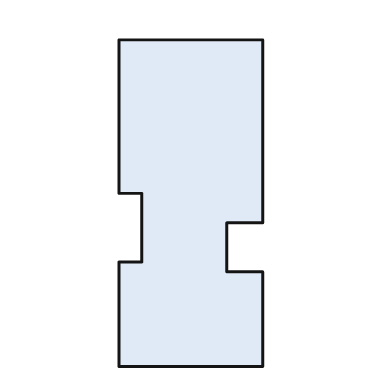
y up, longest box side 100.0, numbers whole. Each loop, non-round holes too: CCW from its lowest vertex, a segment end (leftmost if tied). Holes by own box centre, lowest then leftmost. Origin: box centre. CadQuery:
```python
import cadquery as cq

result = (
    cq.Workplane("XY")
    .moveTo(-22.0, -50.0)
    .lineTo(22.0, -50.0)
    .lineTo(22.0, -21.0)
    .lineTo(11.0, -21.0)
    .lineTo(11.0, -6.0)
    .lineTo(22.0, -6.0)
    .lineTo(22.0, 50.0)
    .lineTo(-22.0, 50.0)
    .lineTo(-22.0, 3.0)
    .lineTo(-15.0, 3.0)
    .lineTo(-15.0, -18.0)
    .lineTo(-22.0, -18.0)
    .close()
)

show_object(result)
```